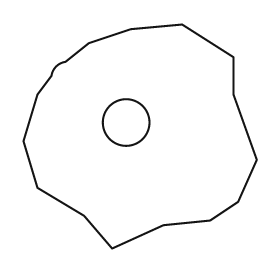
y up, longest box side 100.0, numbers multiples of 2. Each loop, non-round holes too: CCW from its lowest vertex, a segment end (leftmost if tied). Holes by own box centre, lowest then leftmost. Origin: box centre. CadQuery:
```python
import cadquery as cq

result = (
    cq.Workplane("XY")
    .moveTo(-12.0, -48.0)
    .lineTo(10.0, -38.0)
    .lineTo(30.0, -36.0)
    .lineTo(42.0, -28.0)
    .lineTo(50.0, -10.0)
    .lineTo(40.0, 18.0)
    .lineTo(40.0, 34.0)
    .lineTo(18.0, 48.0)
    .lineTo(-4.0, 46.0)
    .lineTo(-22.0, 40.0)
    .lineTo(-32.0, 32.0)
    .threePointArc((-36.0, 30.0), (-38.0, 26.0))
    .lineTo(-44.0, 18.0)
    .lineTo(-50.0, -2.0)
    .lineTo(-44.0, -22.0)
    .lineTo(-24.0, -34.0)
    .close()
    .moveTo(-6.0, 6.0)
    .circle(10.0)
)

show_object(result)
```